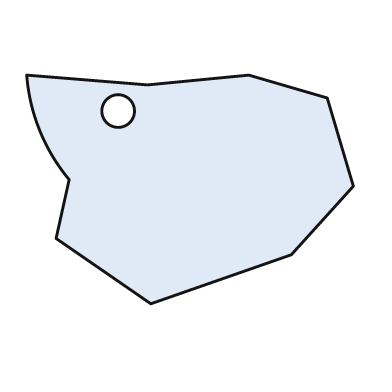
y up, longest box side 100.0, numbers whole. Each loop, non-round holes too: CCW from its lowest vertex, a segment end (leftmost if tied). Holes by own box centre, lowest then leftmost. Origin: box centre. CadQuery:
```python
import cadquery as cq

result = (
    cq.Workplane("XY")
    .moveTo(-12.0, -35.0)
    .lineTo(31.0, -20.0)
    .lineTo(50.0, 1.0)
    .lineTo(42.0, 28.0)
    .lineTo(18.0, 35.0)
    .lineTo(-13.0, 32.0)
    .lineTo(-50.0, 35.0)
    .threePointArc((-46.0, 18.0), (-37.0, 3.0))
    .lineTo(-41.0, -15.0)
    .close()
    .moveTo(-22.0, 24.0)
    .circle(5.0)
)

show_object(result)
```